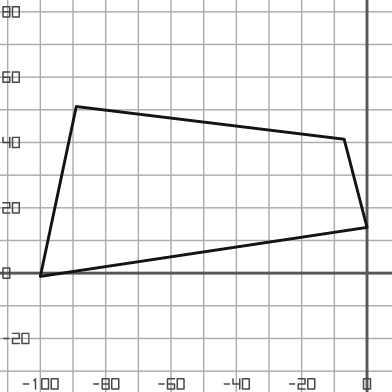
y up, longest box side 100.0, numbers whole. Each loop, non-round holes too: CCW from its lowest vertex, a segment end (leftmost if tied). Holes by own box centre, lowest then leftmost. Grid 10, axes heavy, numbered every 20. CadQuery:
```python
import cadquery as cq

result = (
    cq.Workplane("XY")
    .moveTo(-100.0, -1.0)
    .lineTo(0.0, 14.0)
    .lineTo(-7.0, 41.0)
    .lineTo(-89.0, 51.0)
    .close()
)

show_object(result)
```